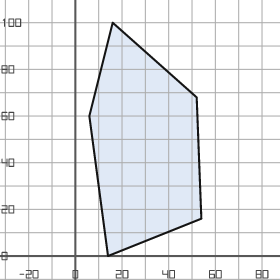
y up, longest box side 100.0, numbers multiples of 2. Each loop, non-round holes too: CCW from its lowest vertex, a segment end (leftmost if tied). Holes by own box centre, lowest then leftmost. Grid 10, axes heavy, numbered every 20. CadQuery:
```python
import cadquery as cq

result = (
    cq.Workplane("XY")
    .moveTo(14.0, 0.0)
    .lineTo(54.0, 16.0)
    .lineTo(52.0, 68.0)
    .lineTo(16.0, 100.0)
    .lineTo(6.0, 60.0)
    .close()
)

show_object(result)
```